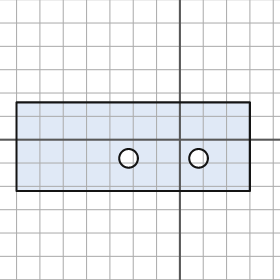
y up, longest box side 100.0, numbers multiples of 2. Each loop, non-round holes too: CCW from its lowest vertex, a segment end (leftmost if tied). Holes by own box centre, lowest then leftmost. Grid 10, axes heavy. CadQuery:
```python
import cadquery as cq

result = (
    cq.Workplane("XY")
    .moveTo(-70.0, -22.0)
    .lineTo(30.0, -22.0)
    .lineTo(30.0, 16.0)
    .lineTo(-70.0, 16.0)
    .close()
    .moveTo(-22.0, -8.0)
    .circle(4.0)
    .moveTo(8.0, -8.0)
    .circle(4.0)
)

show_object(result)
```